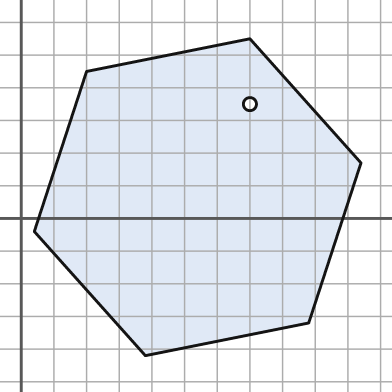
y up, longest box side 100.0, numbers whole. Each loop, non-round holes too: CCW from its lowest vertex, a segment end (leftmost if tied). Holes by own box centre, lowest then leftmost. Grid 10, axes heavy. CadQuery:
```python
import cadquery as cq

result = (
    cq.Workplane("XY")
    .moveTo(38.0, -42.0)
    .lineTo(88.0, -32.0)
    .lineTo(104.0, 17.0)
    .lineTo(70.0, 55.0)
    .lineTo(20.0, 45.0)
    .lineTo(4.0, -4.0)
    .close()
    .moveTo(70.0, 35.0)
    .circle(2.0)
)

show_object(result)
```